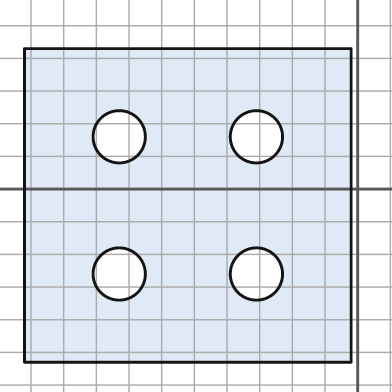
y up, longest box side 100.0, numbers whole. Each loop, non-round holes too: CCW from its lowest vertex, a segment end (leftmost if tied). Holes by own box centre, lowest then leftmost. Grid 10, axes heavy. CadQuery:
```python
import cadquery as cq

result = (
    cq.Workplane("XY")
    .moveTo(-102.0, -53.0)
    .lineTo(-2.0, -53.0)
    .lineTo(-2.0, 43.0)
    .lineTo(-102.0, 43.0)
    .close()
    .moveTo(-73.0, -26.0)
    .circle(8.0)
    .moveTo(-31.0, -26.0)
    .circle(8.0)
    .moveTo(-73.0, 16.0)
    .circle(8.0)
    .moveTo(-31.0, 16.0)
    .circle(8.0)
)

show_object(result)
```